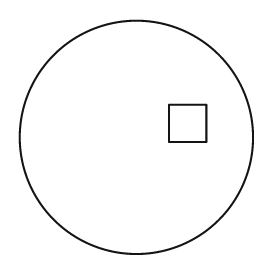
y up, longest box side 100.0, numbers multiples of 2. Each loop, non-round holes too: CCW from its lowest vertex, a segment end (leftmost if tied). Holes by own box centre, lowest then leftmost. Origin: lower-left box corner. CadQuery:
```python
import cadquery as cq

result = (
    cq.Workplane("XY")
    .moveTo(50.0, 50.0)
    .circle(50.0)
    .moveTo(64.0, 48.0)
    .lineTo(80.0, 48.0)
    .lineTo(80.0, 64.0)
    .lineTo(64.0, 64.0)
    .close()
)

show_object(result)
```